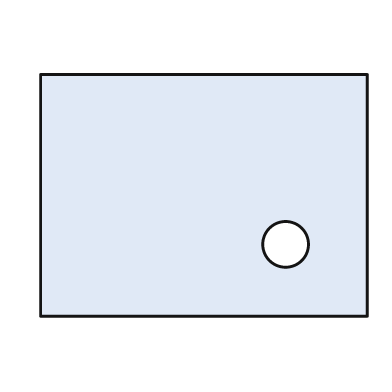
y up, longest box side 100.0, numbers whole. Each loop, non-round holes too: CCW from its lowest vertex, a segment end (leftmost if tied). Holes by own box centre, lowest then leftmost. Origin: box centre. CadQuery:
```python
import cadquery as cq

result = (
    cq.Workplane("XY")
    .moveTo(-50.0, -37.0)
    .lineTo(50.0, -37.0)
    .lineTo(50.0, 37.0)
    .lineTo(-50.0, 37.0)
    .close()
    .moveTo(25.0, -15.0)
    .circle(7.0)
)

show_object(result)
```